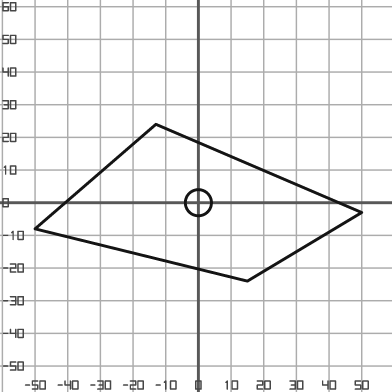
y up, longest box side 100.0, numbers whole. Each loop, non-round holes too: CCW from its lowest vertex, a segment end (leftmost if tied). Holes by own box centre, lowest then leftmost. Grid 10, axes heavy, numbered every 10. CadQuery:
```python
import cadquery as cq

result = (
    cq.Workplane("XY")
    .moveTo(15.0, -24.0)
    .lineTo(50.0, -3.0)
    .lineTo(-13.0, 24.0)
    .lineTo(-50.0, -8.0)
    .close()
    .moveTo(0.0, 0.0)
    .circle(4.0)
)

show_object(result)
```